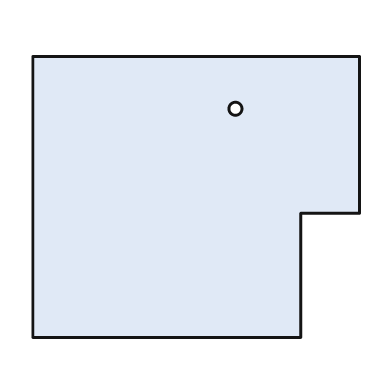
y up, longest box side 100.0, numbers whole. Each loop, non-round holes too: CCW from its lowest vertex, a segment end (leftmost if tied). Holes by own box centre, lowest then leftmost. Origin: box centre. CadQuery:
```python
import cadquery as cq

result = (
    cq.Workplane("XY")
    .moveTo(-50.0, -43.0)
    .lineTo(32.0, -43.0)
    .lineTo(32.0, -5.0)
    .lineTo(50.0, -5.0)
    .lineTo(50.0, 43.0)
    .lineTo(-50.0, 43.0)
    .close()
    .moveTo(12.0, 27.0)
    .circle(2.0)
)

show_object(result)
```